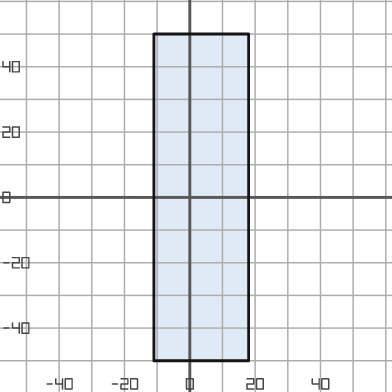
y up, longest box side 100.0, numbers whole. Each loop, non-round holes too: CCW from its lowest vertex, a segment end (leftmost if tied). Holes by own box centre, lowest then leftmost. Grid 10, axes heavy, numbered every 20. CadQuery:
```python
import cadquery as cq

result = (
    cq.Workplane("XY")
    .moveTo(-11.0, -50.0)
    .lineTo(18.0, -50.0)
    .lineTo(18.0, 50.0)
    .lineTo(-11.0, 50.0)
    .close()
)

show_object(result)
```